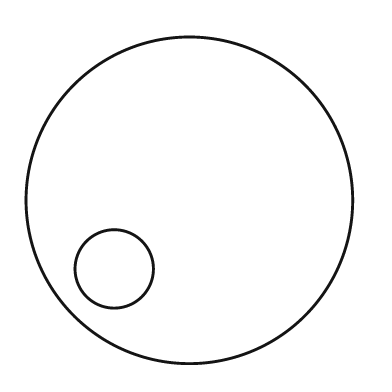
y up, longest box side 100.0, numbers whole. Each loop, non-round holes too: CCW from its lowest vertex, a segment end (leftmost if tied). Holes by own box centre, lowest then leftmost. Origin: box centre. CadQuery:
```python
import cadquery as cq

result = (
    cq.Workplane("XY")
    .moveTo(0.0, 0.0)
    .circle(50.0)
    .moveTo(-23.0, -21.0)
    .circle(12.0)
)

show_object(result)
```